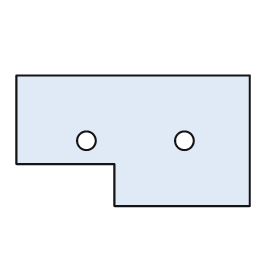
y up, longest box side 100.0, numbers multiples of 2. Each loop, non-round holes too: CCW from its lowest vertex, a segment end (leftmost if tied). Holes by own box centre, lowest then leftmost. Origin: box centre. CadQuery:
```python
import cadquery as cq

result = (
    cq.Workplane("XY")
    .moveTo(-8.0, -28.0)
    .lineTo(50.0, -28.0)
    .lineTo(50.0, 28.0)
    .lineTo(-50.0, 28.0)
    .lineTo(-50.0, -10.0)
    .lineTo(-8.0, -10.0)
    .close()
    .moveTo(-20.0, 0.0)
    .circle(4.0)
    .moveTo(22.0, 0.0)
    .circle(4.0)
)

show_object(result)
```